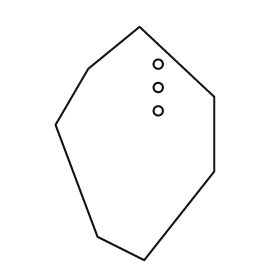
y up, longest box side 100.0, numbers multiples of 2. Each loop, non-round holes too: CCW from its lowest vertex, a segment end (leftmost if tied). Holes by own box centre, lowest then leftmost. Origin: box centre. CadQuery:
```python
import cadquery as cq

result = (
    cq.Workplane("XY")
    .moveTo(4.0, -50.0)
    .lineTo(34.0, -12.0)
    .lineTo(34.0, 20.0)
    .lineTo(2.0, 50.0)
    .lineTo(-20.0, 32.0)
    .lineTo(-34.0, 8.0)
    .lineTo(-16.0, -40.0)
    .close()
    .moveTo(10.0, 14.0)
    .circle(2.0)
    .moveTo(10.0, 24.0)
    .circle(2.0)
    .moveTo(10.0, 34.0)
    .circle(2.0)
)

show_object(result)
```